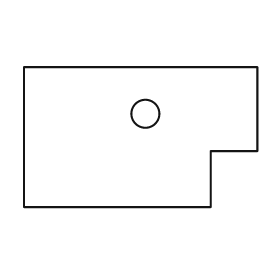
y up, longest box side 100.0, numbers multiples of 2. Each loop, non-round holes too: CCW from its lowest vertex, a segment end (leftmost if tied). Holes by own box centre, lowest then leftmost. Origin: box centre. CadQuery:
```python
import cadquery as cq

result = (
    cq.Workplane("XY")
    .moveTo(-50.0, -30.0)
    .lineTo(30.0, -30.0)
    .lineTo(30.0, -6.0)
    .lineTo(50.0, -6.0)
    .lineTo(50.0, 30.0)
    .lineTo(-50.0, 30.0)
    .close()
    .moveTo(2.0, 10.0)
    .circle(6.0)
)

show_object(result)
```